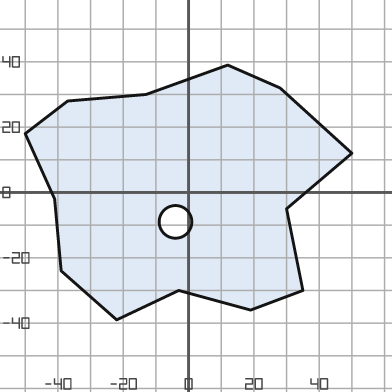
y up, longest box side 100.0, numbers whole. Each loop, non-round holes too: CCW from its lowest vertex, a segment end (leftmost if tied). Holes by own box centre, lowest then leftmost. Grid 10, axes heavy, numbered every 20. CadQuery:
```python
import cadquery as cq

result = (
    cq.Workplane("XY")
    .moveTo(-22.0, -39.0)
    .lineTo(-3.0, -30.0)
    .lineTo(19.0, -36.0)
    .lineTo(35.0, -30.0)
    .lineTo(30.0, -5.0)
    .lineTo(50.0, 12.0)
    .lineTo(28.0, 32.0)
    .lineTo(12.0, 39.0)
    .lineTo(-13.0, 30.0)
    .lineTo(-37.0, 28.0)
    .lineTo(-50.0, 18.0)
    .lineTo(-41.0, -2.0)
    .lineTo(-39.0, -24.0)
    .close()
    .moveTo(-4.0, -9.0)
    .circle(5.0)
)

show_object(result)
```